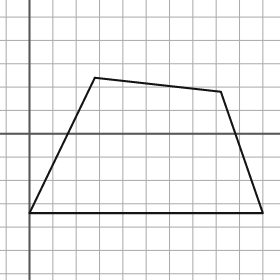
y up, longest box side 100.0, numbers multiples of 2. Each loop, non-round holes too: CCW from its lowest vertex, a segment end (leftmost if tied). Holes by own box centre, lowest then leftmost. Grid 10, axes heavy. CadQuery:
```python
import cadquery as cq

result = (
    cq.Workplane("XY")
    .moveTo(0.0, -34.0)
    .lineTo(100.0, -34.0)
    .lineTo(82.0, 18.0)
    .lineTo(28.0, 24.0)
    .close()
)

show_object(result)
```